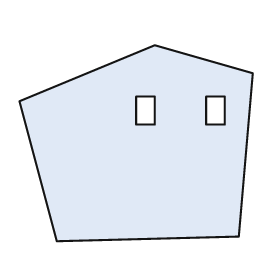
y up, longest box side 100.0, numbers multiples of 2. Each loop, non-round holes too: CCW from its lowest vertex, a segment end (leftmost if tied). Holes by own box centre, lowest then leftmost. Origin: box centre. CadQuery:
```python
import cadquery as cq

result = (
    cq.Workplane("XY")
    .moveTo(-34.0, -42.0)
    .lineTo(44.0, -40.0)
    .lineTo(50.0, 30.0)
    .lineTo(8.0, 42.0)
    .lineTo(-50.0, 18.0)
    .close()
    .moveTo(0.0, 8.0)
    .lineTo(8.0, 8.0)
    .lineTo(8.0, 20.0)
    .lineTo(0.0, 20.0)
    .close()
    .moveTo(30.0, 8.0)
    .lineTo(38.0, 8.0)
    .lineTo(38.0, 20.0)
    .lineTo(30.0, 20.0)
    .close()
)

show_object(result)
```